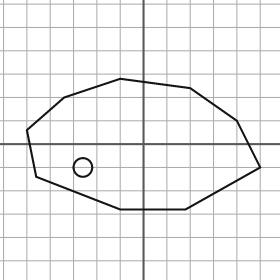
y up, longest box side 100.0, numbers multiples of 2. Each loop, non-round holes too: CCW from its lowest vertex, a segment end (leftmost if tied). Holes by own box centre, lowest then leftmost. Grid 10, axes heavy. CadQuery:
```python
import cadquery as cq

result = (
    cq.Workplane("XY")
    .moveTo(-10.0, -28.0)
    .lineTo(18.0, -28.0)
    .lineTo(50.0, -10.0)
    .lineTo(40.0, 10.0)
    .lineTo(20.0, 24.0)
    .lineTo(-10.0, 28.0)
    .lineTo(-34.0, 20.0)
    .lineTo(-50.0, 6.0)
    .lineTo(-46.0, -14.0)
    .close()
    .moveTo(-26.0, -10.0)
    .circle(4.0)
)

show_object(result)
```